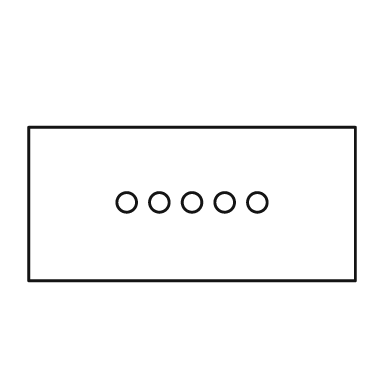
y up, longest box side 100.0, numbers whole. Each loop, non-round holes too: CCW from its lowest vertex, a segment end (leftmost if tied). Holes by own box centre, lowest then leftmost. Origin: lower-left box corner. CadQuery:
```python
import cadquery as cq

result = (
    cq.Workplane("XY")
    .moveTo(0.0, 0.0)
    .lineTo(100.0, 0.0)
    .lineTo(100.0, 47.0)
    .lineTo(0.0, 47.0)
    .close()
    .moveTo(30.0, 24.0)
    .circle(3.0)
    .moveTo(40.0, 24.0)
    .circle(3.0)
    .moveTo(50.0, 24.0)
    .circle(3.0)
    .moveTo(60.0, 24.0)
    .circle(3.0)
    .moveTo(70.0, 24.0)
    .circle(3.0)
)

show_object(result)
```